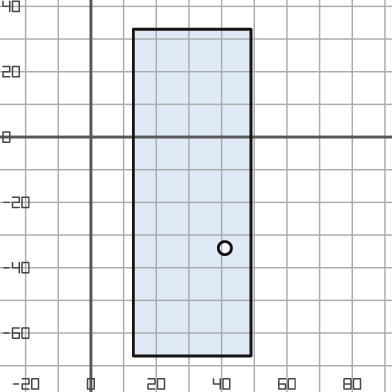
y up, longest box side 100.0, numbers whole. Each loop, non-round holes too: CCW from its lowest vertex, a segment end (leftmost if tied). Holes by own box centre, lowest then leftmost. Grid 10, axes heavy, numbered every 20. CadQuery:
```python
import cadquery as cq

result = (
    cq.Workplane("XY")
    .moveTo(13.0, -67.0)
    .lineTo(49.0, -67.0)
    .lineTo(49.0, 33.0)
    .lineTo(13.0, 33.0)
    .close()
    .moveTo(41.0, -34.0)
    .circle(2.0)
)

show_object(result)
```